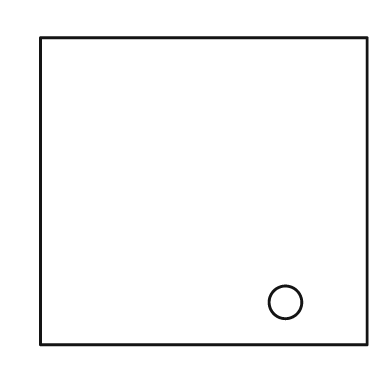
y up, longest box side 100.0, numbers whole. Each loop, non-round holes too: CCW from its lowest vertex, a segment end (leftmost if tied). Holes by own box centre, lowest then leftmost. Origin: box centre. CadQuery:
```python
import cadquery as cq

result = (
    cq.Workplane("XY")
    .moveTo(-50.0, -47.0)
    .lineTo(50.0, -47.0)
    .lineTo(50.0, 47.0)
    .lineTo(-50.0, 47.0)
    .close()
    .moveTo(25.0, -34.0)
    .circle(5.0)
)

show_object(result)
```